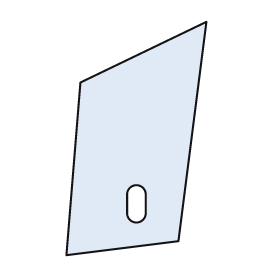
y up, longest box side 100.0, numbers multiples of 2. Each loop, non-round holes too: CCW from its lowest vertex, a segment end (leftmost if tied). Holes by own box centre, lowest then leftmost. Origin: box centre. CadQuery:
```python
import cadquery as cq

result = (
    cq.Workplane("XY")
    .moveTo(-30.0, -50.0)
    .lineTo(18.0, -44.0)
    .lineTo(30.0, 50.0)
    .lineTo(-24.0, 24.0)
    .close()
    .moveTo(-4.0, -32.0)
    .threePointArc((0.0, -36.0), (4.0, -32.0))
    .lineTo(4.0, -24.0)
    .threePointArc((0.0, -20.0), (-4.0, -24.0))
    .close()
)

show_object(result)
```